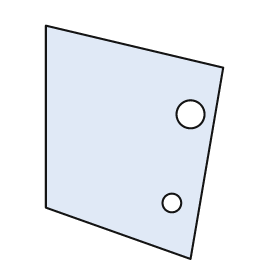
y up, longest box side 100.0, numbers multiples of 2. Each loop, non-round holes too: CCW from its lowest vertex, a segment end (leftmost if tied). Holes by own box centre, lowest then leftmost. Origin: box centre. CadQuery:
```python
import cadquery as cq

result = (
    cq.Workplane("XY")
    .moveTo(24.0, -50.0)
    .lineTo(38.0, 32.0)
    .lineTo(-38.0, 50.0)
    .lineTo(-38.0, -28.0)
    .close()
    .moveTo(16.0, -26.0)
    .circle(4.0)
    .moveTo(24.0, 12.0)
    .circle(6.0)
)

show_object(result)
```